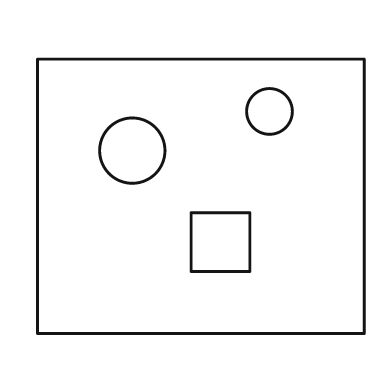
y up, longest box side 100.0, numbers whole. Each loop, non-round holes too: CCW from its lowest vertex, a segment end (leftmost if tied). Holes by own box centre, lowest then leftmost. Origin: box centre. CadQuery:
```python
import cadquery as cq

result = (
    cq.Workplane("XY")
    .moveTo(-50.0, -42.0)
    .lineTo(50.0, -42.0)
    .lineTo(50.0, 42.0)
    .lineTo(-50.0, 42.0)
    .close()
    .moveTo(-3.0, -23.0)
    .lineTo(15.0, -23.0)
    .lineTo(15.0, -5.0)
    .lineTo(-3.0, -5.0)
    .close()
    .moveTo(-21.0, 14.0)
    .circle(10.0)
    .moveTo(21.0, 26.0)
    .circle(7.0)
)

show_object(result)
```